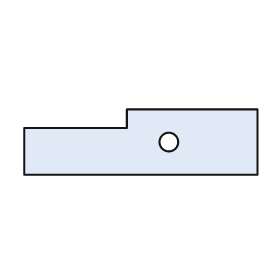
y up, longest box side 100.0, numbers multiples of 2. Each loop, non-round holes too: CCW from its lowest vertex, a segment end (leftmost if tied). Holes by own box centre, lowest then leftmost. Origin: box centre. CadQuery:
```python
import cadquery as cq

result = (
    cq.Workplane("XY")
    .moveTo(-50.0, -14.0)
    .lineTo(50.0, -14.0)
    .lineTo(50.0, 14.0)
    .lineTo(-6.0, 14.0)
    .lineTo(-6.0, 6.0)
    .lineTo(-50.0, 6.0)
    .close()
    .moveTo(12.0, 0.0)
    .circle(4.0)
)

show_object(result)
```